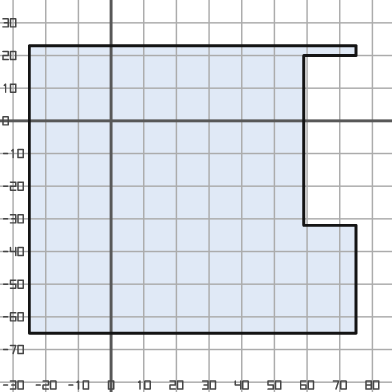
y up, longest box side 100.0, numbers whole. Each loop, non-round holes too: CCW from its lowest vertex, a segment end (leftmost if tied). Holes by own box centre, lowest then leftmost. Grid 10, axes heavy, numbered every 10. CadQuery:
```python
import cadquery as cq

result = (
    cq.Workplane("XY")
    .moveTo(-25.0, -65.0)
    .lineTo(75.0, -65.0)
    .lineTo(75.0, -32.0)
    .lineTo(59.0, -32.0)
    .lineTo(59.0, 20.0)
    .lineTo(75.0, 20.0)
    .lineTo(75.0, 23.0)
    .lineTo(-25.0, 23.0)
    .close()
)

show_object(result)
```